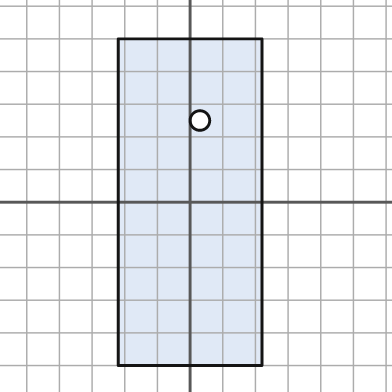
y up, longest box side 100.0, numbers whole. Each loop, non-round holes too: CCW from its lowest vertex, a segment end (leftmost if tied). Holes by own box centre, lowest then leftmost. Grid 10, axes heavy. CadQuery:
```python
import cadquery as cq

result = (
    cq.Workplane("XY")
    .moveTo(-22.0, -50.0)
    .lineTo(22.0, -50.0)
    .lineTo(22.0, 50.0)
    .lineTo(-22.0, 50.0)
    .close()
    .moveTo(3.0, 25.0)
    .circle(3.0)
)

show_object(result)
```